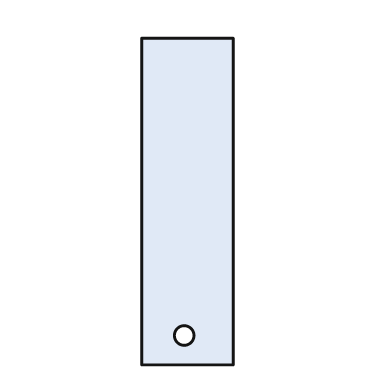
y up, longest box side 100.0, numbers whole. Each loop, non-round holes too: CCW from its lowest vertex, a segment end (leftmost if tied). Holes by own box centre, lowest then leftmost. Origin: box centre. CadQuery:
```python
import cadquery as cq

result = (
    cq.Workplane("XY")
    .moveTo(-14.0, -50.0)
    .lineTo(14.0, -50.0)
    .lineTo(14.0, 50.0)
    .lineTo(-14.0, 50.0)
    .close()
    .moveTo(-1.0, -41.0)
    .circle(3.0)
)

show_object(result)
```